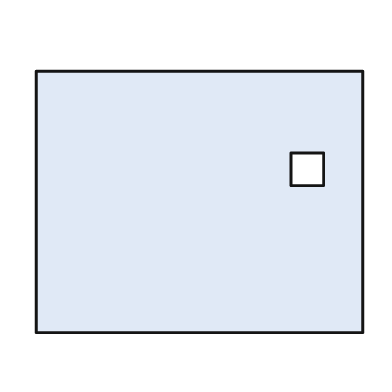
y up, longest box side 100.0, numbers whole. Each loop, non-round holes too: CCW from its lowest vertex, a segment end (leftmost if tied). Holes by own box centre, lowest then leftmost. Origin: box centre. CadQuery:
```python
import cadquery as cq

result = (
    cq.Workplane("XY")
    .moveTo(-50.0, -40.0)
    .lineTo(50.0, -40.0)
    .lineTo(50.0, 40.0)
    .lineTo(-50.0, 40.0)
    .close()
    .moveTo(28.0, 5.0)
    .lineTo(38.0, 5.0)
    .lineTo(38.0, 15.0)
    .lineTo(28.0, 15.0)
    .close()
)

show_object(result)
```